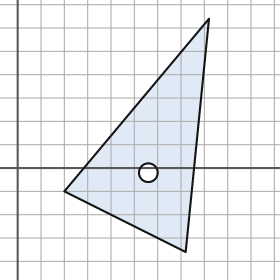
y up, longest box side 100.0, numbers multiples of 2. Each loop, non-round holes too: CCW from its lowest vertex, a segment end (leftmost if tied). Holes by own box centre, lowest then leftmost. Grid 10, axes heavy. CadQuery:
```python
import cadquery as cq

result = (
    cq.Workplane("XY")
    .moveTo(72.0, -36.0)
    .lineTo(82.0, 64.0)
    .lineTo(20.0, -10.0)
    .close()
    .moveTo(56.0, -2.0)
    .circle(4.0)
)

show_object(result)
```